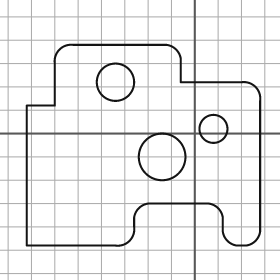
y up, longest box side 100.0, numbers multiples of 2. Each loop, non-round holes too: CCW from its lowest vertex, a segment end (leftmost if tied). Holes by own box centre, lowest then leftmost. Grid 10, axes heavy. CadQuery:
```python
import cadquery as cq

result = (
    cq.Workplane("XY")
    .moveTo(-72.0, -48.0)
    .lineTo(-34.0, -48.0)
    .threePointArc((-28.0, -46.0), (-26.0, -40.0))
    .lineTo(-26.0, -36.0)
    .threePointArc((-24.0, -32.0), (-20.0, -30.0))
    .lineTo(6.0, -30.0)
    .threePointArc((10.0, -32.0), (12.0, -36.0))
    .lineTo(12.0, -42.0)
    .threePointArc((14.0, -46.0), (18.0, -48.0))
    .lineTo(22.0, -48.0)
    .threePointArc((26.0, -46.0), (28.0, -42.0))
    .lineTo(28.0, 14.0)
    .threePointArc((26.0, 20.0), (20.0, 22.0))
    .lineTo(-6.0, 22.0)
    .lineTo(-6.0, 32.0)
    .threePointArc((-8.0, 36.0), (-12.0, 38.0))
    .lineTo(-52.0, 38.0)
    .threePointArc((-58.0, 36.0), (-60.0, 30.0))
    .lineTo(-60.0, 12.0)
    .lineTo(-72.0, 12.0)
    .close()
    .moveTo(-14.0, -10.0)
    .circle(10.0)
    .moveTo(8.0, 2.0)
    .circle(6.0)
    .moveTo(-34.0, 22.0)
    .circle(8.0)
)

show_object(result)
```